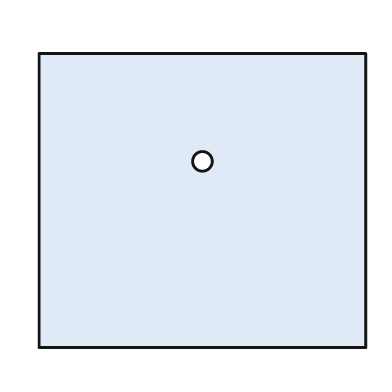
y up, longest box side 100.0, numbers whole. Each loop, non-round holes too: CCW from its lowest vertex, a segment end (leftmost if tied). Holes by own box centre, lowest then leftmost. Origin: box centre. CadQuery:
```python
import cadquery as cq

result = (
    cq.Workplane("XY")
    .moveTo(-50.0, -45.0)
    .lineTo(50.0, -45.0)
    .lineTo(50.0, 45.0)
    .lineTo(-50.0, 45.0)
    .close()
    .moveTo(0.0, 12.0)
    .circle(3.0)
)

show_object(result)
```